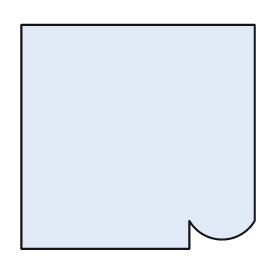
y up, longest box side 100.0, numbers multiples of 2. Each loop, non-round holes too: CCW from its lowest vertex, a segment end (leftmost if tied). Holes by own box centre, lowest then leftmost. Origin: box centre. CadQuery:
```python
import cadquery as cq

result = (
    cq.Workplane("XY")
    .moveTo(-50.0, -48.0)
    .lineTo(22.0, -48.0)
    .lineTo(22.0, -36.0)
    .threePointArc((36.0, -44.0), (50.0, -36.0))
    .lineTo(50.0, 48.0)
    .lineTo(-50.0, 48.0)
    .close()
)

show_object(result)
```